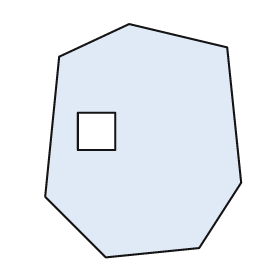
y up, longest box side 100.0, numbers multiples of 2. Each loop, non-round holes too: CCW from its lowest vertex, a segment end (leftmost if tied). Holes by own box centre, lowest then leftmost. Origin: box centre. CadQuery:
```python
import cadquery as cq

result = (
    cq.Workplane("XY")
    .moveTo(-16.0, -50.0)
    .lineTo(24.0, -46.0)
    .lineTo(42.0, -18.0)
    .lineTo(36.0, 40.0)
    .lineTo(-6.0, 50.0)
    .lineTo(-36.0, 36.0)
    .lineTo(-42.0, -24.0)
    .close()
    .moveTo(-28.0, -4.0)
    .lineTo(-12.0, -4.0)
    .lineTo(-12.0, 12.0)
    .lineTo(-28.0, 12.0)
    .close()
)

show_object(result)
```